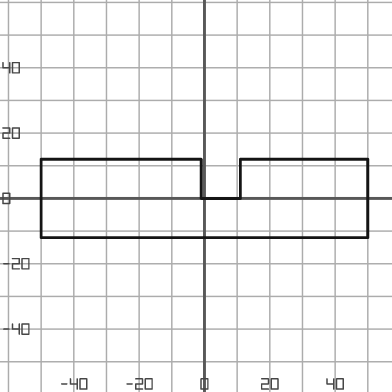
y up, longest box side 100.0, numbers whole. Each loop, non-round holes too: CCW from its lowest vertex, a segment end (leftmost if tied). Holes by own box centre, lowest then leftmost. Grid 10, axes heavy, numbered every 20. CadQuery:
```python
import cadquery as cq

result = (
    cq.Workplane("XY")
    .moveTo(-50.0, -12.0)
    .lineTo(50.0, -12.0)
    .lineTo(50.0, 12.0)
    .lineTo(11.0, 12.0)
    .lineTo(11.0, 0.0)
    .lineTo(-1.0, 0.0)
    .lineTo(-1.0, 12.0)
    .lineTo(-50.0, 12.0)
    .close()
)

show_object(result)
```